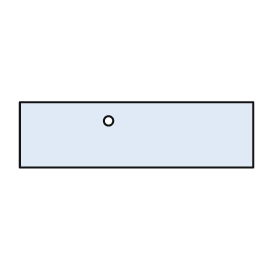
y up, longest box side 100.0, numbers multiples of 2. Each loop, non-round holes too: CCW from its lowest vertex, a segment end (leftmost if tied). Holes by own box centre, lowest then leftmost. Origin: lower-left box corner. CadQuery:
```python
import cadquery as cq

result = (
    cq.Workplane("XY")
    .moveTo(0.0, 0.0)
    .lineTo(100.0, 0.0)
    .lineTo(100.0, 28.0)
    .lineTo(0.0, 28.0)
    .close()
    .moveTo(38.0, 20.0)
    .circle(2.0)
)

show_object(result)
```